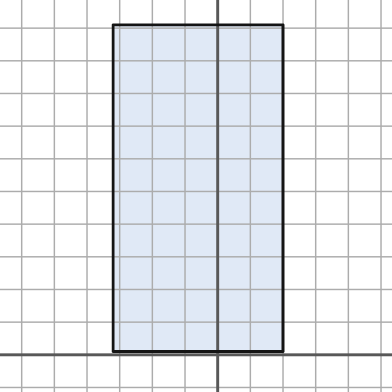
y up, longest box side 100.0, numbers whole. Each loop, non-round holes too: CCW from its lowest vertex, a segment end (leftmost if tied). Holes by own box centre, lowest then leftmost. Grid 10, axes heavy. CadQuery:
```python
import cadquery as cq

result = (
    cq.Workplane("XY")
    .moveTo(-32.0, 1.0)
    .lineTo(20.0, 1.0)
    .lineTo(20.0, 101.0)
    .lineTo(-32.0, 101.0)
    .close()
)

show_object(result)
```